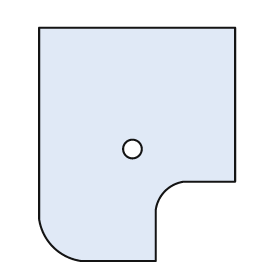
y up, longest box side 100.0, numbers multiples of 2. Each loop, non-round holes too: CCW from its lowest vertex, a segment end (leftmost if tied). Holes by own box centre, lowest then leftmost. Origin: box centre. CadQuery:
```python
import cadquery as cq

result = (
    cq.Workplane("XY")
    .moveTo(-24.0, -50.0)
    .lineTo(8.0, -50.0)
    .lineTo(8.0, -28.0)
    .threePointArc((12.0, -20.0), (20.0, -16.0))
    .lineTo(42.0, -16.0)
    .lineTo(42.0, 50.0)
    .lineTo(-42.0, 50.0)
    .lineTo(-42.0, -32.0)
    .threePointArc((-36.0, -44.0), (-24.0, -50.0))
    .close()
    .moveTo(-2.0, -2.0)
    .circle(4.0)
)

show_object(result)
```